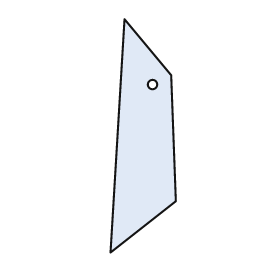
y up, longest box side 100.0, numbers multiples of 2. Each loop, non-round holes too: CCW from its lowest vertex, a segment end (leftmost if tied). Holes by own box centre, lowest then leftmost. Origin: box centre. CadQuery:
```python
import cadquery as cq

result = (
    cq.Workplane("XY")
    .moveTo(-14.0, -50.0)
    .lineTo(14.0, -28.0)
    .lineTo(12.0, 26.0)
    .lineTo(-8.0, 50.0)
    .close()
    .moveTo(4.0, 22.0)
    .circle(2.0)
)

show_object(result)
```